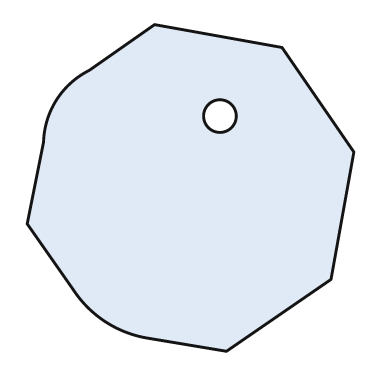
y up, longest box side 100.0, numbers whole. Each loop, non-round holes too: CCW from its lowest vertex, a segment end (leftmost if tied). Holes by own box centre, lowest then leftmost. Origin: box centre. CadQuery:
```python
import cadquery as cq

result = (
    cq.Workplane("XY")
    .moveTo(11.0, -50.0)
    .lineTo(43.0, -28.0)
    .lineTo(50.0, 11.0)
    .lineTo(28.0, 43.0)
    .lineTo(-11.0, 50.0)
    .lineTo(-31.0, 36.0)
    .threePointArc((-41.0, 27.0), (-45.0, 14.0))
    .lineTo(-50.0, -11.0)
    .lineTo(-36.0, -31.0)
    .threePointArc((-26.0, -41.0), (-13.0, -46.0))
    .close()
    .moveTo(9.0, 22.0)
    .circle(5.0)
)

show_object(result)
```